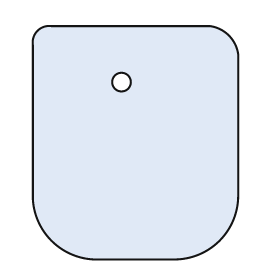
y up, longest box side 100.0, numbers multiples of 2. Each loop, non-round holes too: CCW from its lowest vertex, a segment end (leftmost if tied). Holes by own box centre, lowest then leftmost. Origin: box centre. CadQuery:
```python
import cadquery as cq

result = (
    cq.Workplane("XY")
    .moveTo(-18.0, -50.0)
    .lineTo(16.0, -50.0)
    .threePointArc((36.0, -42.0), (44.0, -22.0))
    .lineTo(44.0, 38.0)
    .threePointArc((40.0, 46.0), (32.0, 50.0))
    .lineTo(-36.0, 50.0)
    .threePointArc((-42.0, 48.0), (-44.0, 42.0))
    .lineTo(-44.0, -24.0)
    .threePointArc((-36.0, -42.0), (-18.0, -50.0))
    .close()
    .moveTo(-6.0, 26.0)
    .circle(4.0)
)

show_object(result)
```